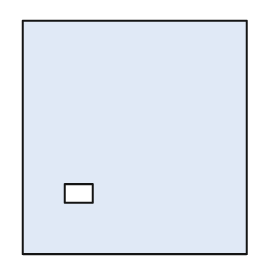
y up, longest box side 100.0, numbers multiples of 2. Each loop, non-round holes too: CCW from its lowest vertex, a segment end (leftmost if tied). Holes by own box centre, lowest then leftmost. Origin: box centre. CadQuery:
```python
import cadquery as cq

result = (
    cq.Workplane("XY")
    .moveTo(-48.0, -50.0)
    .lineTo(48.0, -50.0)
    .lineTo(48.0, 50.0)
    .lineTo(-48.0, 50.0)
    .close()
    .moveTo(-30.0, -28.0)
    .lineTo(-18.0, -28.0)
    .lineTo(-18.0, -20.0)
    .lineTo(-30.0, -20.0)
    .close()
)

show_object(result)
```